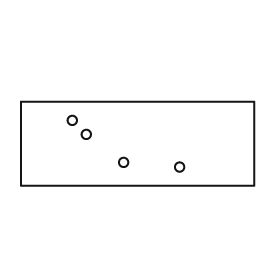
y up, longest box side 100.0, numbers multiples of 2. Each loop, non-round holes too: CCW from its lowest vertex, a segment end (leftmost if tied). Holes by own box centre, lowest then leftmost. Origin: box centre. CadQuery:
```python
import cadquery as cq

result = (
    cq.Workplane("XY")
    .moveTo(-50.0, -18.0)
    .lineTo(50.0, -18.0)
    .lineTo(50.0, 18.0)
    .lineTo(-50.0, 18.0)
    .close()
    .moveTo(18.0, -10.0)
    .circle(2.0)
    .moveTo(-6.0, -8.0)
    .circle(2.0)
    .moveTo(-22.0, 4.0)
    .circle(2.0)
    .moveTo(-28.0, 10.0)
    .circle(2.0)
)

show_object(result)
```